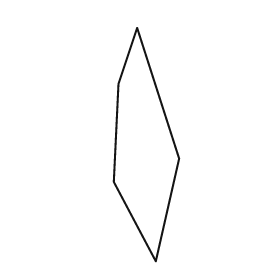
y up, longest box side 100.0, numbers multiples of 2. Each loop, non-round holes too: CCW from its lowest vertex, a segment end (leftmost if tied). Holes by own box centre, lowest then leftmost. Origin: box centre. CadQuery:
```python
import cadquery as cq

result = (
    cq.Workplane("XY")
    .moveTo(4.0, -50.0)
    .lineTo(14.0, -6.0)
    .lineTo(-4.0, 50.0)
    .lineTo(-12.0, 26.0)
    .lineTo(-14.0, -16.0)
    .close()
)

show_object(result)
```